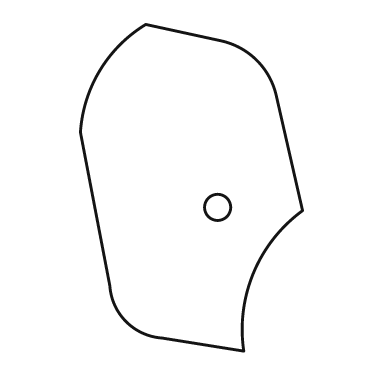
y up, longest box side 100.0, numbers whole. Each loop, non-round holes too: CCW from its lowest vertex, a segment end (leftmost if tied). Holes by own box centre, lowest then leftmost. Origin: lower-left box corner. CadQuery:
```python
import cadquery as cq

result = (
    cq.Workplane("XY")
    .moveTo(50.0, 0.0)
    .threePointArc((53.0, 24.0), (68.0, 43.0))
    .lineTo(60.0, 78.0)
    .threePointArc((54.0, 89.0), (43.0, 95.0))
    .lineTo(20.0, 100.0)
    .threePointArc((6.0, 86.0), (0.0, 67.0))
    .lineTo(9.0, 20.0)
    .threePointArc((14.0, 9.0), (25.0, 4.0))
    .close()
    .moveTo(42.0, 44.0)
    .circle(4.0)
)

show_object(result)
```